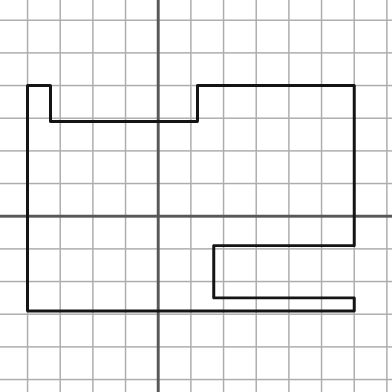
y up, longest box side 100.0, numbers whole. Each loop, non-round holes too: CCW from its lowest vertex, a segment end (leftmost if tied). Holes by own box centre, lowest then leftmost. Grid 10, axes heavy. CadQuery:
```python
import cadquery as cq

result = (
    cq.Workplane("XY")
    .moveTo(-40.0, -29.0)
    .lineTo(60.0, -29.0)
    .lineTo(60.0, -25.0)
    .lineTo(17.0, -25.0)
    .lineTo(17.0, -9.0)
    .lineTo(60.0, -9.0)
    .lineTo(60.0, 40.0)
    .lineTo(12.0, 40.0)
    .lineTo(12.0, 29.0)
    .lineTo(-33.0, 29.0)
    .lineTo(-33.0, 40.0)
    .lineTo(-40.0, 40.0)
    .close()
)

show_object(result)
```